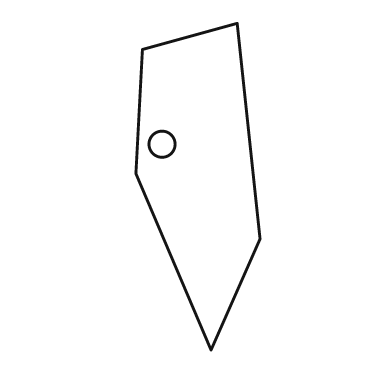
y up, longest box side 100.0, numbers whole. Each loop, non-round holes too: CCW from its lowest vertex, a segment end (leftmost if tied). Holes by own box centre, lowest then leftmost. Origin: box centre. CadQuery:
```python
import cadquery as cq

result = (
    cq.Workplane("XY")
    .moveTo(4.0, -50.0)
    .lineTo(19.0, -16.0)
    .lineTo(12.0, 50.0)
    .lineTo(-17.0, 42.0)
    .lineTo(-19.0, 4.0)
    .close()
    .moveTo(-11.0, 13.0)
    .circle(4.0)
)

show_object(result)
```